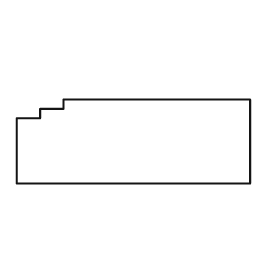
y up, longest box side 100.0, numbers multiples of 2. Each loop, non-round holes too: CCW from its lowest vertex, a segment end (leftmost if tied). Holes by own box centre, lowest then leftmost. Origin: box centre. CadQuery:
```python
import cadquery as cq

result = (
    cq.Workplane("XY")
    .moveTo(-50.0, -18.0)
    .lineTo(50.0, -18.0)
    .lineTo(50.0, 18.0)
    .lineTo(-30.0, 18.0)
    .lineTo(-30.0, 14.0)
    .lineTo(-40.0, 14.0)
    .lineTo(-40.0, 10.0)
    .lineTo(-50.0, 10.0)
    .close()
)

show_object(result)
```